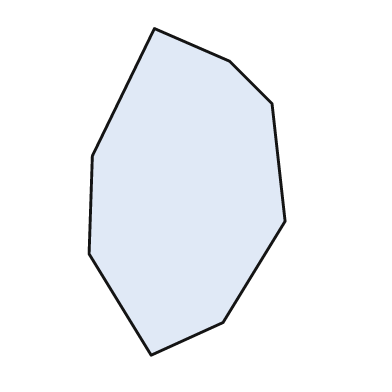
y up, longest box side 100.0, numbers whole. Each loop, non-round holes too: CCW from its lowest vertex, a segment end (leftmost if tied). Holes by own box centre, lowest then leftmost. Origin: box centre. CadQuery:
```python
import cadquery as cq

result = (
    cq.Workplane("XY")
    .moveTo(-11.0, -50.0)
    .lineTo(11.0, -40.0)
    .lineTo(30.0, -9.0)
    .lineTo(26.0, 27.0)
    .lineTo(13.0, 40.0)
    .lineTo(-10.0, 50.0)
    .lineTo(-29.0, 11.0)
    .lineTo(-30.0, -19.0)
    .close()
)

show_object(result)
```